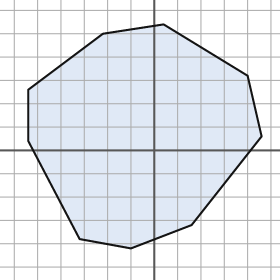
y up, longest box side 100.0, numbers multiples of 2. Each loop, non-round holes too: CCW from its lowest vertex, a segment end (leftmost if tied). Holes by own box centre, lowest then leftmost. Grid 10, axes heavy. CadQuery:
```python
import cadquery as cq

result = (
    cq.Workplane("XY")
    .moveTo(-10.0, -42.0)
    .lineTo(16.0, -32.0)
    .lineTo(46.0, 6.0)
    .lineTo(40.0, 32.0)
    .lineTo(4.0, 54.0)
    .lineTo(-22.0, 50.0)
    .lineTo(-54.0, 26.0)
    .lineTo(-54.0, 4.0)
    .lineTo(-32.0, -38.0)
    .close()
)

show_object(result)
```